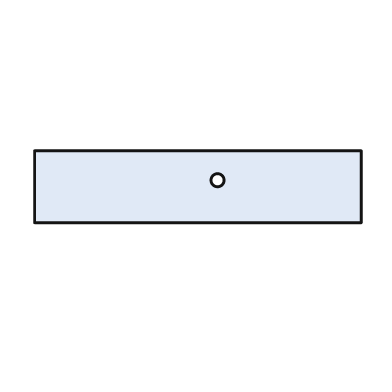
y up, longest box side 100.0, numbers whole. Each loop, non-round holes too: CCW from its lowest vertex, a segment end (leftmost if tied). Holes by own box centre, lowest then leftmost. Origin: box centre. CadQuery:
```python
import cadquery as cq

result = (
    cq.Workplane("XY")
    .moveTo(-50.0, -11.0)
    .lineTo(50.0, -11.0)
    .lineTo(50.0, 11.0)
    .lineTo(-50.0, 11.0)
    .close()
    .moveTo(6.0, 2.0)
    .circle(2.0)
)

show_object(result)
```